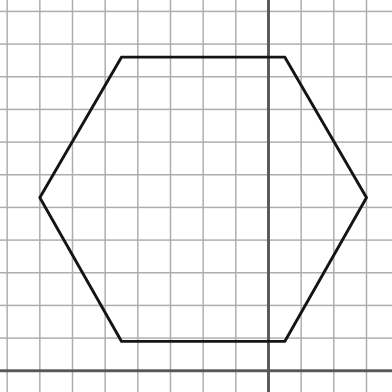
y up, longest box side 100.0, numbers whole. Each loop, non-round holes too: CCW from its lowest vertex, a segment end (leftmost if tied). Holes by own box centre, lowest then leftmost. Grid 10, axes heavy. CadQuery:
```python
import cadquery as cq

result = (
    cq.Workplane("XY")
    .moveTo(-45.0, 9.0)
    .lineTo(5.0, 9.0)
    .lineTo(30.0, 53.0)
    .lineTo(5.0, 96.0)
    .lineTo(-45.0, 96.0)
    .lineTo(-70.0, 53.0)
    .close()
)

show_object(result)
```